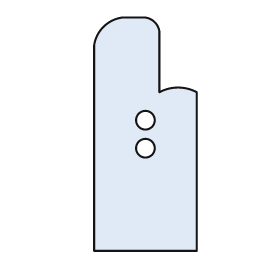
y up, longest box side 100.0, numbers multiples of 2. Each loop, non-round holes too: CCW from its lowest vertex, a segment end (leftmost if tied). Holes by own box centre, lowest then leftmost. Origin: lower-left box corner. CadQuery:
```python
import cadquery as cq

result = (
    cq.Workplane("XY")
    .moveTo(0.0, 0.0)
    .lineTo(44.0, 0.0)
    .lineTo(44.0, 68.0)
    .threePointArc((36.0, 70.0), (28.0, 68.0))
    .lineTo(28.0, 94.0)
    .threePointArc((26.0, 98.0), (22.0, 100.0))
    .lineTo(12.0, 100.0)
    .threePointArc((4.0, 96.0), (0.0, 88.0))
    .close()
    .moveTo(22.0, 44.0)
    .circle(4.0)
    .moveTo(22.0, 56.0)
    .circle(4.0)
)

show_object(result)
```